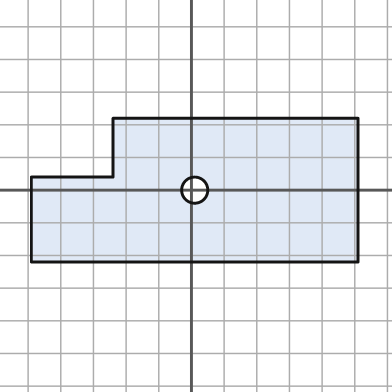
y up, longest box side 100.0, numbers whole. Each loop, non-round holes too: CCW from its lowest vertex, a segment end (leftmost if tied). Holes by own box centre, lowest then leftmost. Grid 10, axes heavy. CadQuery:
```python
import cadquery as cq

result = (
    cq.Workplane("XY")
    .moveTo(-49.0, -22.0)
    .lineTo(51.0, -22.0)
    .lineTo(51.0, 22.0)
    .lineTo(-24.0, 22.0)
    .lineTo(-24.0, 4.0)
    .lineTo(-49.0, 4.0)
    .close()
    .moveTo(1.0, 0.0)
    .circle(4.0)
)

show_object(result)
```